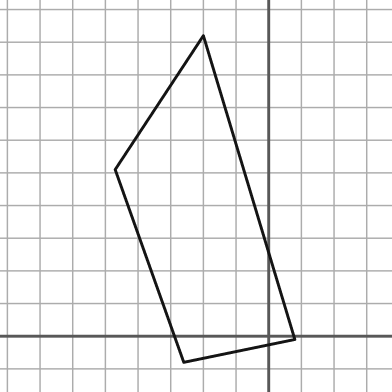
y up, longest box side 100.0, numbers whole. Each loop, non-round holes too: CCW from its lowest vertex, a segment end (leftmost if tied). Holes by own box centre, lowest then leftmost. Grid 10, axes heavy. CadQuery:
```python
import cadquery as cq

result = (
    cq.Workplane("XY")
    .moveTo(-26.0, -8.0)
    .lineTo(8.0, -1.0)
    .lineTo(-20.0, 92.0)
    .lineTo(-47.0, 51.0)
    .close()
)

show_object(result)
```